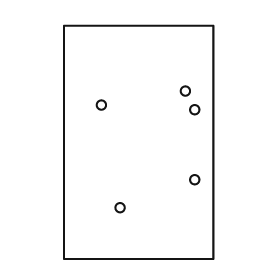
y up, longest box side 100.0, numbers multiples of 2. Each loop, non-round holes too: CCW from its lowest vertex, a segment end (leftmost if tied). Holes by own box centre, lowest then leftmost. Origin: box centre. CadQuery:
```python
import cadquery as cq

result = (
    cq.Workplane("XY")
    .moveTo(-32.0, -50.0)
    .lineTo(32.0, -50.0)
    .lineTo(32.0, 50.0)
    .lineTo(-32.0, 50.0)
    .close()
    .moveTo(-8.0, -28.0)
    .circle(2.0)
    .moveTo(24.0, -16.0)
    .circle(2.0)
    .moveTo(24.0, 14.0)
    .circle(2.0)
    .moveTo(-16.0, 16.0)
    .circle(2.0)
    .moveTo(20.0, 22.0)
    .circle(2.0)
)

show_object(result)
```